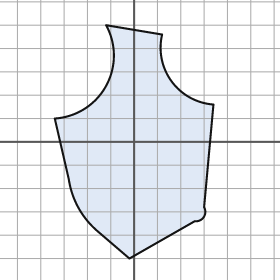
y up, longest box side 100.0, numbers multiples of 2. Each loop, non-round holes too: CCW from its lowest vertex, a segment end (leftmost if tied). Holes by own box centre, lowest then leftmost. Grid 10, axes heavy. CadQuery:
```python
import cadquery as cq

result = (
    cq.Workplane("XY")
    .moveTo(-2.0, -50.0)
    .lineTo(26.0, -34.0)
    .threePointArc((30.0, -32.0), (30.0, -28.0))
    .lineTo(34.0, 16.0)
    .threePointArc((16.0, 26.0), (12.0, 46.0))
    .lineTo(-12.0, 50.0)
    .threePointArc((-12.0, 24.0), (-34.0, 10.0))
    .lineTo(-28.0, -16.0)
    .threePointArc((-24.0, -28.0), (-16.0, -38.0))
    .close()
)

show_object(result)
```